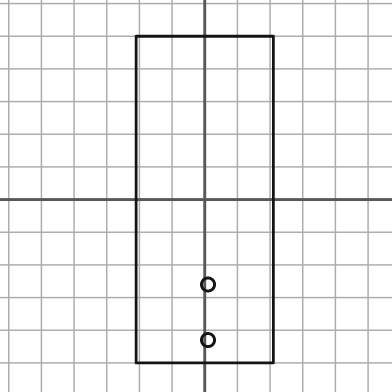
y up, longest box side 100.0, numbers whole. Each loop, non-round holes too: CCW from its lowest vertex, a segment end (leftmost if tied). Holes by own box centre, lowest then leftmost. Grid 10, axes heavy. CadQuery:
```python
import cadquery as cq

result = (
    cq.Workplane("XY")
    .moveTo(-21.0, -50.0)
    .lineTo(21.0, -50.0)
    .lineTo(21.0, 50.0)
    .lineTo(-21.0, 50.0)
    .close()
    .moveTo(1.0, -43.0)
    .circle(2.0)
    .moveTo(1.0, -26.0)
    .circle(2.0)
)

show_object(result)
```